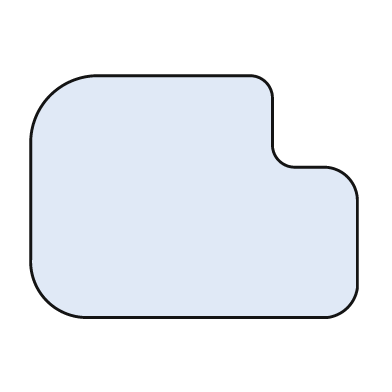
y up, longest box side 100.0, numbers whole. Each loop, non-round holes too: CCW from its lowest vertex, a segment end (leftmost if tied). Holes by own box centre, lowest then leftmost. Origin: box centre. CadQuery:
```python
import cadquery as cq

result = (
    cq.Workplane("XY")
    .moveTo(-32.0, -37.0)
    .lineTo(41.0, -37.0)
    .threePointArc((47.0, -34.0), (50.0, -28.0))
    .lineTo(50.0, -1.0)
    .threePointArc((47.0, 6.0), (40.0, 9.0))
    .lineTo(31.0, 9.0)
    .threePointArc((26.0, 11.0), (24.0, 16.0))
    .lineTo(24.0, 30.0)
    .threePointArc((22.0, 35.0), (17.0, 37.0))
    .lineTo(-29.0, 37.0)
    .threePointArc((-44.0, 31.0), (-50.0, 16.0))
    .lineTo(-50.0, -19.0)
    .threePointArc((-45.0, -32.0), (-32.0, -37.0))
    .close()
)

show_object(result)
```